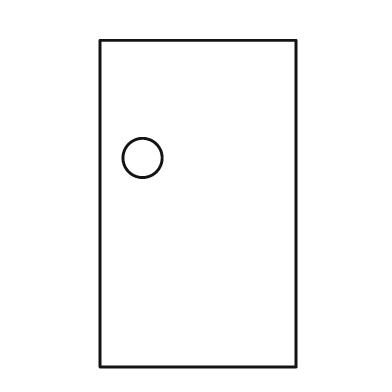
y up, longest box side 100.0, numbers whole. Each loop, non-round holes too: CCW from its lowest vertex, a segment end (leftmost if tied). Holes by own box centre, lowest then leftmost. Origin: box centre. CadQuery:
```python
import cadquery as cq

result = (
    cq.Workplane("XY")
    .moveTo(-30.0, -50.0)
    .lineTo(30.0, -50.0)
    .lineTo(30.0, 50.0)
    .lineTo(-30.0, 50.0)
    .close()
    .moveTo(-17.0, 14.0)
    .circle(6.0)
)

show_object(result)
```